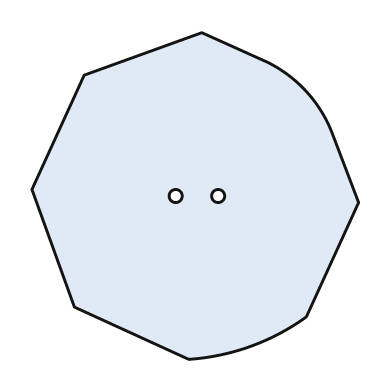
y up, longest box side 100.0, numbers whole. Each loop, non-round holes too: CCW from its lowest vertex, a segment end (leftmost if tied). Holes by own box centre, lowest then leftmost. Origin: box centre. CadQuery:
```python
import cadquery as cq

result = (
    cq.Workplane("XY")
    .moveTo(-2.0, -50.0)
    .threePointArc((17.0, -46.0), (34.0, -37.0))
    .lineTo(50.0, -2.0)
    .lineTo(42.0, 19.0)
    .threePointArc((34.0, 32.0), (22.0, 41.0))
    .lineTo(2.0, 50.0)
    .lineTo(-34.0, 37.0)
    .lineTo(-50.0, 2.0)
    .lineTo(-37.0, -34.0)
    .close()
    .moveTo(-6.0, 0.0)
    .circle(2.0)
    .moveTo(7.0, 0.0)
    .circle(2.0)
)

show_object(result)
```